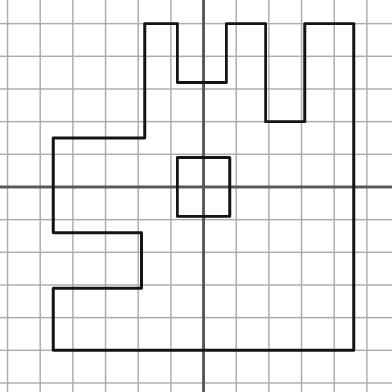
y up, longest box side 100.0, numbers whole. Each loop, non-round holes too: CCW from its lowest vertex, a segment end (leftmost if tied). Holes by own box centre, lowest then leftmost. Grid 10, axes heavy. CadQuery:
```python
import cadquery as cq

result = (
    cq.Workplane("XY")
    .moveTo(-46.0, -50.0)
    .lineTo(46.0, -50.0)
    .lineTo(46.0, 50.0)
    .lineTo(31.0, 50.0)
    .lineTo(31.0, 20.0)
    .lineTo(19.0, 20.0)
    .lineTo(19.0, 50.0)
    .lineTo(7.0, 50.0)
    .lineTo(7.0, 32.0)
    .lineTo(-8.0, 32.0)
    .lineTo(-8.0, 50.0)
    .lineTo(-18.0, 50.0)
    .lineTo(-18.0, 15.0)
    .lineTo(-46.0, 15.0)
    .lineTo(-46.0, -14.0)
    .lineTo(-19.0, -14.0)
    .lineTo(-19.0, -31.0)
    .lineTo(-46.0, -31.0)
    .close()
    .moveTo(-8.0, -9.0)
    .lineTo(8.0, -9.0)
    .lineTo(8.0, 9.0)
    .lineTo(-8.0, 9.0)
    .close()
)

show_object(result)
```